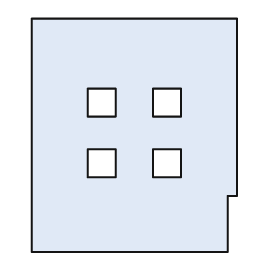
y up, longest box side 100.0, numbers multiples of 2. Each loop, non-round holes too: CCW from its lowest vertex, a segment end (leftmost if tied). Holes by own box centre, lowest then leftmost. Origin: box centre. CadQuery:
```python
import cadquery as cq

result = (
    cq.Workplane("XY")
    .moveTo(-44.0, -50.0)
    .lineTo(40.0, -50.0)
    .lineTo(40.0, -26.0)
    .lineTo(44.0, -26.0)
    .lineTo(44.0, 50.0)
    .lineTo(-44.0, 50.0)
    .close()
    .moveTo(-20.0, -18.0)
    .lineTo(-8.0, -18.0)
    .lineTo(-8.0, -6.0)
    .lineTo(-20.0, -6.0)
    .close()
    .moveTo(8.0, -18.0)
    .lineTo(20.0, -18.0)
    .lineTo(20.0, -6.0)
    .lineTo(8.0, -6.0)
    .close()
    .moveTo(-20.0, 8.0)
    .lineTo(-8.0, 8.0)
    .lineTo(-8.0, 20.0)
    .lineTo(-20.0, 20.0)
    .close()
    .moveTo(8.0, 8.0)
    .lineTo(20.0, 8.0)
    .lineTo(20.0, 20.0)
    .lineTo(8.0, 20.0)
    .close()
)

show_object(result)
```